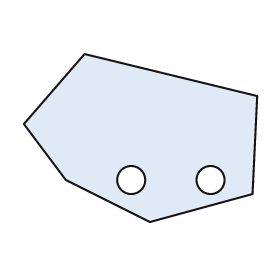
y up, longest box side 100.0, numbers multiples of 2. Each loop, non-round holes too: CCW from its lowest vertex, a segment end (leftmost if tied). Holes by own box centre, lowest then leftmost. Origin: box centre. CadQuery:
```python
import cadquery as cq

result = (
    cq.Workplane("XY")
    .moveTo(4.0, -36.0)
    .lineTo(48.0, -24.0)
    .lineTo(50.0, 18.0)
    .lineTo(-24.0, 36.0)
    .lineTo(-50.0, 6.0)
    .lineTo(-32.0, -18.0)
    .close()
    .moveTo(-4.0, -18.0)
    .circle(6.0)
    .moveTo(30.0, -18.0)
    .circle(6.0)
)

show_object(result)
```